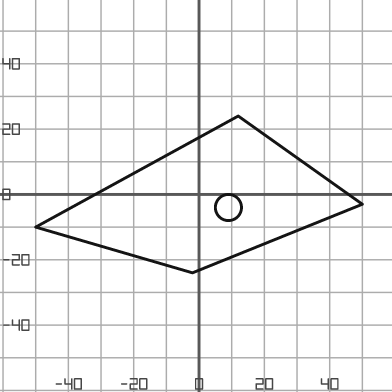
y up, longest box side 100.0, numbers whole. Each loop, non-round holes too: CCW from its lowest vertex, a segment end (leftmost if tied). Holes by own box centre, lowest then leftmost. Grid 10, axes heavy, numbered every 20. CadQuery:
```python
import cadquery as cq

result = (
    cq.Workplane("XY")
    .moveTo(-2.0, -24.0)
    .lineTo(50.0, -3.0)
    .lineTo(12.0, 24.0)
    .lineTo(-50.0, -10.0)
    .close()
    .moveTo(9.0, -4.0)
    .circle(4.0)
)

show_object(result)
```